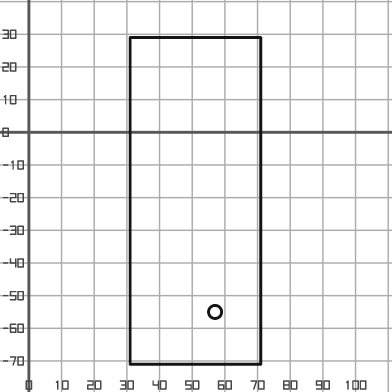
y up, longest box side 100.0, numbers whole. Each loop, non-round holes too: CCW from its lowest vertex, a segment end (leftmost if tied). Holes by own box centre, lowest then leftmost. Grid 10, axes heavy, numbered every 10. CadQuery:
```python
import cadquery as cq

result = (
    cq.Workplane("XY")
    .moveTo(31.0, -71.0)
    .lineTo(71.0, -71.0)
    .lineTo(71.0, 29.0)
    .lineTo(31.0, 29.0)
    .close()
    .moveTo(57.0, -55.0)
    .circle(2.0)
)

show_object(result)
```